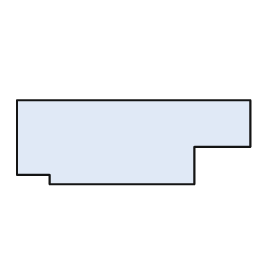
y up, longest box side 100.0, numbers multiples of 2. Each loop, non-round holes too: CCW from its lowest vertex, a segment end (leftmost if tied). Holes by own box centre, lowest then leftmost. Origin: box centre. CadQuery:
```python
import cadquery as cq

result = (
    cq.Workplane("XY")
    .moveTo(-36.0, -18.0)
    .lineTo(26.0, -18.0)
    .lineTo(26.0, -2.0)
    .lineTo(50.0, -2.0)
    .lineTo(50.0, 18.0)
    .lineTo(-50.0, 18.0)
    .lineTo(-50.0, -14.0)
    .lineTo(-36.0, -14.0)
    .close()
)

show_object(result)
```